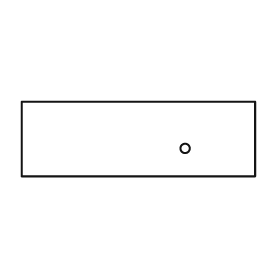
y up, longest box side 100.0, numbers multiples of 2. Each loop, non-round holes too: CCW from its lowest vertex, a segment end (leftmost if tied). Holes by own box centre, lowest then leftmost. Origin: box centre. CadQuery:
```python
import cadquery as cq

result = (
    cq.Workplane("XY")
    .moveTo(-50.0, -16.0)
    .lineTo(50.0, -16.0)
    .lineTo(50.0, 16.0)
    .lineTo(-50.0, 16.0)
    .close()
    .moveTo(20.0, -4.0)
    .circle(2.0)
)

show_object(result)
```